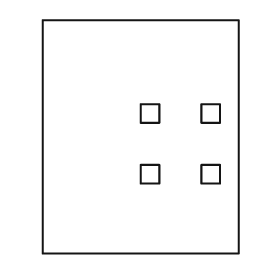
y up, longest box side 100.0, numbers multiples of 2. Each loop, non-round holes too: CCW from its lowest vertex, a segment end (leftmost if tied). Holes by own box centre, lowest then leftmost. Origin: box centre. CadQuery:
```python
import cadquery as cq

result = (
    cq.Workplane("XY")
    .moveTo(-42.0, -50.0)
    .lineTo(42.0, -50.0)
    .lineTo(42.0, 50.0)
    .lineTo(-42.0, 50.0)
    .close()
    .moveTo(0.0, -20.0)
    .lineTo(8.0, -20.0)
    .lineTo(8.0, -12.0)
    .lineTo(0.0, -12.0)
    .close()
    .moveTo(26.0, -20.0)
    .lineTo(34.0, -20.0)
    .lineTo(34.0, -12.0)
    .lineTo(26.0, -12.0)
    .close()
    .moveTo(0.0, 6.0)
    .lineTo(8.0, 6.0)
    .lineTo(8.0, 14.0)
    .lineTo(0.0, 14.0)
    .close()
    .moveTo(26.0, 6.0)
    .lineTo(34.0, 6.0)
    .lineTo(34.0, 14.0)
    .lineTo(26.0, 14.0)
    .close()
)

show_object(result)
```